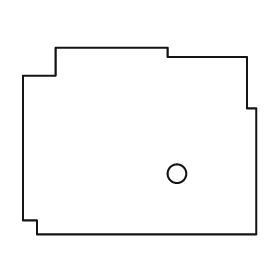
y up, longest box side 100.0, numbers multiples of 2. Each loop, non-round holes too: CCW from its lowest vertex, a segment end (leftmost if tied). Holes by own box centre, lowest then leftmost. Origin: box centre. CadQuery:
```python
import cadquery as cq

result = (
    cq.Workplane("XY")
    .moveTo(-44.0, -40.0)
    .lineTo(50.0, -40.0)
    .lineTo(50.0, 14.0)
    .lineTo(46.0, 14.0)
    .lineTo(46.0, 36.0)
    .lineTo(12.0, 36.0)
    .lineTo(12.0, 40.0)
    .lineTo(-36.0, 40.0)
    .lineTo(-36.0, 28.0)
    .lineTo(-50.0, 28.0)
    .lineTo(-50.0, -34.0)
    .lineTo(-44.0, -34.0)
    .close()
    .moveTo(16.0, -14.0)
    .circle(4.0)
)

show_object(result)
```